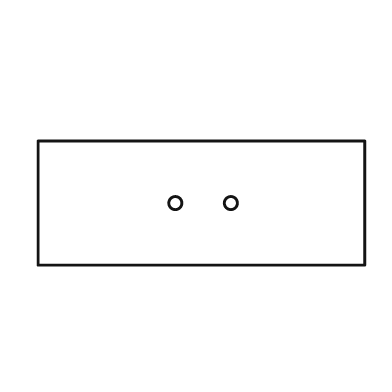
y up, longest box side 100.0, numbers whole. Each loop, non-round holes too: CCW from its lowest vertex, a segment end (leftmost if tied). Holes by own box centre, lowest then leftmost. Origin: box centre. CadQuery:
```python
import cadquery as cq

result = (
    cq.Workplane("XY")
    .moveTo(-50.0, -19.0)
    .lineTo(50.0, -19.0)
    .lineTo(50.0, 19.0)
    .lineTo(-50.0, 19.0)
    .close()
    .moveTo(-8.0, 0.0)
    .circle(2.0)
    .moveTo(9.0, 0.0)
    .circle(2.0)
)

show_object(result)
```